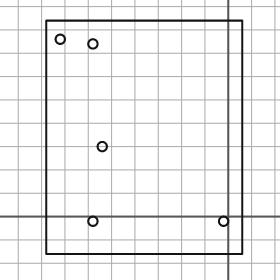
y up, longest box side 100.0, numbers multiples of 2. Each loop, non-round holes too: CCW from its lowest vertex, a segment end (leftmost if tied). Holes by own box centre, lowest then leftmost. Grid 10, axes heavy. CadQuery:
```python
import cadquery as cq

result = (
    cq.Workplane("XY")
    .moveTo(-78.0, -16.0)
    .lineTo(6.0, -16.0)
    .lineTo(6.0, 84.0)
    .lineTo(-78.0, 84.0)
    .close()
    .moveTo(-58.0, -2.0)
    .circle(2.0)
    .moveTo(-2.0, -2.0)
    .circle(2.0)
    .moveTo(-54.0, 30.0)
    .circle(2.0)
    .moveTo(-58.0, 74.0)
    .circle(2.0)
    .moveTo(-72.0, 76.0)
    .circle(2.0)
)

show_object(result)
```